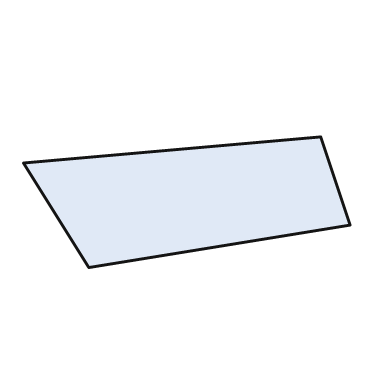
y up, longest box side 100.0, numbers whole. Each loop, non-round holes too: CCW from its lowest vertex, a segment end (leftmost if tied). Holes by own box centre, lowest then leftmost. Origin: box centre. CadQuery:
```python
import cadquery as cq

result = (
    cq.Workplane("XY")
    .moveTo(-30.0, -20.0)
    .lineTo(50.0, -7.0)
    .lineTo(41.0, 20.0)
    .lineTo(-50.0, 12.0)
    .close()
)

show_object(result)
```